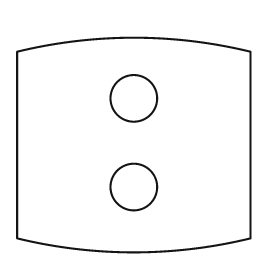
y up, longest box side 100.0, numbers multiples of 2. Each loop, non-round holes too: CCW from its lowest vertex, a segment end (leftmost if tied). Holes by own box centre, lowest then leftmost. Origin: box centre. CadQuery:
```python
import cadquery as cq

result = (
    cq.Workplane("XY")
    .moveTo(-50.0, -40.0)
    .threePointArc((0.0, -46.0), (50.0, -40.0))
    .lineTo(50.0, 40.0)
    .threePointArc((0.0, 46.0), (-50.0, 40.0))
    .close()
    .moveTo(0.0, -18.0)
    .circle(10.0)
    .moveTo(0.0, 20.0)
    .circle(10.0)
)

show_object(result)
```